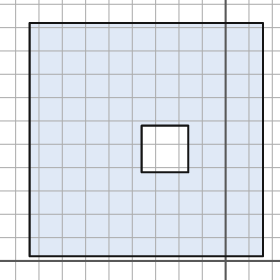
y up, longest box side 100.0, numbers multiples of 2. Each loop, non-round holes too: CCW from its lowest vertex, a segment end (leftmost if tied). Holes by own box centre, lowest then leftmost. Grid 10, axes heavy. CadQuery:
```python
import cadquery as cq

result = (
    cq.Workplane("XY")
    .moveTo(-84.0, 2.0)
    .lineTo(16.0, 2.0)
    .lineTo(16.0, 102.0)
    .lineTo(-84.0, 102.0)
    .close()
    .moveTo(-36.0, 38.0)
    .lineTo(-16.0, 38.0)
    .lineTo(-16.0, 58.0)
    .lineTo(-36.0, 58.0)
    .close()
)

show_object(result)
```